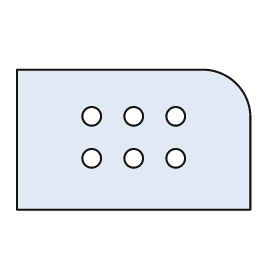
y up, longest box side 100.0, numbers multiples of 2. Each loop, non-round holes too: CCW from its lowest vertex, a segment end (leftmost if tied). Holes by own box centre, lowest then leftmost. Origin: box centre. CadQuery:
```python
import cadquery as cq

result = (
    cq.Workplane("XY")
    .moveTo(-50.0, -30.0)
    .lineTo(50.0, -30.0)
    .lineTo(50.0, 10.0)
    .threePointArc((44.0, 24.0), (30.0, 30.0))
    .lineTo(-50.0, 30.0)
    .close()
    .moveTo(-18.0, -8.0)
    .circle(4.0)
    .moveTo(0.0, -8.0)
    .circle(4.0)
    .moveTo(18.0, -8.0)
    .circle(4.0)
    .moveTo(-18.0, 10.0)
    .circle(4.0)
    .moveTo(0.0, 10.0)
    .circle(4.0)
    .moveTo(18.0, 10.0)
    .circle(4.0)
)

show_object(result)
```